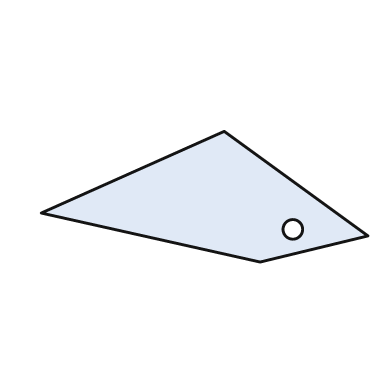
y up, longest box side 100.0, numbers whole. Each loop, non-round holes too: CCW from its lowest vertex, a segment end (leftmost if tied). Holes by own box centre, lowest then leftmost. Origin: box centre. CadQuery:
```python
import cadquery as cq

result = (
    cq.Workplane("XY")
    .moveTo(17.0, -20.0)
    .lineTo(50.0, -12.0)
    .lineTo(6.0, 20.0)
    .lineTo(-50.0, -5.0)
    .close()
    .moveTo(27.0, -10.0)
    .circle(3.0)
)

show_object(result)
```